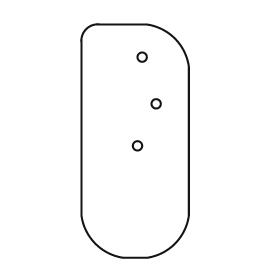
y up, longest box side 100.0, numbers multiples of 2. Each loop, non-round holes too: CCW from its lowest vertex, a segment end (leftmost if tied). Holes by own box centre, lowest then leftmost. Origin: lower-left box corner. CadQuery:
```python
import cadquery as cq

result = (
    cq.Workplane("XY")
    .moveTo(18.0, 0.0)
    .lineTo(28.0, 0.0)
    .threePointArc((40.0, 6.0), (46.0, 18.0))
    .lineTo(46.0, 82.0)
    .threePointArc((40.0, 94.0), (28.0, 100.0))
    .lineTo(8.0, 100.0)
    .threePointArc((2.0, 98.0), (0.0, 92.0))
    .lineTo(0.0, 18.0)
    .threePointArc((6.0, 6.0), (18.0, 0.0))
    .close()
    .moveTo(24.0, 48.0)
    .circle(2.0)
    .moveTo(32.0, 66.0)
    .circle(2.0)
    .moveTo(26.0, 86.0)
    .circle(2.0)
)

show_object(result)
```